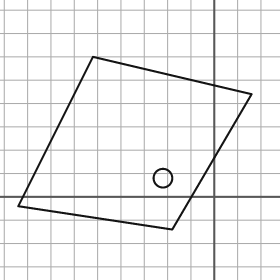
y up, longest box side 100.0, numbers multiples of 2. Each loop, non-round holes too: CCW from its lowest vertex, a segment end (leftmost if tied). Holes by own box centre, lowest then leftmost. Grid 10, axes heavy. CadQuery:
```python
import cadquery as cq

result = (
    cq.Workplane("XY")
    .moveTo(-18.0, -14.0)
    .lineTo(16.0, 44.0)
    .lineTo(-52.0, 60.0)
    .lineTo(-84.0, -4.0)
    .close()
    .moveTo(-22.0, 8.0)
    .circle(4.0)
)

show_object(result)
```